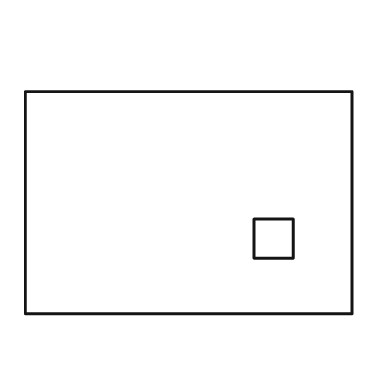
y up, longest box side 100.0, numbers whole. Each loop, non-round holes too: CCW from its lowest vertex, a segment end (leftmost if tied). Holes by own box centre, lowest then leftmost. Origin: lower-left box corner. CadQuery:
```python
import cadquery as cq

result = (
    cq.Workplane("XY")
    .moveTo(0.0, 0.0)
    .lineTo(100.0, 0.0)
    .lineTo(100.0, 68.0)
    .lineTo(0.0, 68.0)
    .close()
    .moveTo(70.0, 17.0)
    .lineTo(82.0, 17.0)
    .lineTo(82.0, 29.0)
    .lineTo(70.0, 29.0)
    .close()
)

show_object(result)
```